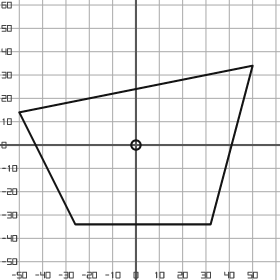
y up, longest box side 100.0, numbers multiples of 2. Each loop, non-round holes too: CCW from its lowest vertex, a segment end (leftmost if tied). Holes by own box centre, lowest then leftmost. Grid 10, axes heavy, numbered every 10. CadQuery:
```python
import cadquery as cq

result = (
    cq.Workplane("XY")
    .moveTo(-26.0, -34.0)
    .lineTo(32.0, -34.0)
    .lineTo(50.0, 34.0)
    .lineTo(-50.0, 14.0)
    .close()
    .moveTo(0.0, 0.0)
    .circle(2.0)
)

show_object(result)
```